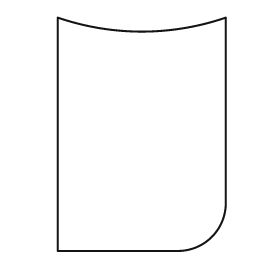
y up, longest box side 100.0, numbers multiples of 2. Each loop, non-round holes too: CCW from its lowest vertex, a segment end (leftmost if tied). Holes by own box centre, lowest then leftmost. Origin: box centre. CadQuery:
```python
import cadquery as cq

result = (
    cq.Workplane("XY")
    .moveTo(-36.0, -50.0)
    .lineTo(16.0, -50.0)
    .threePointArc((30.0, -44.0), (36.0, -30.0))
    .lineTo(36.0, 50.0)
    .threePointArc((0.0, 44.0), (-36.0, 50.0))
    .close()
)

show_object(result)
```